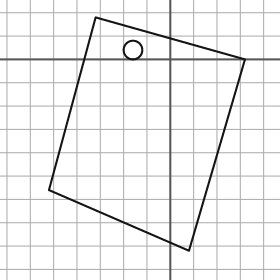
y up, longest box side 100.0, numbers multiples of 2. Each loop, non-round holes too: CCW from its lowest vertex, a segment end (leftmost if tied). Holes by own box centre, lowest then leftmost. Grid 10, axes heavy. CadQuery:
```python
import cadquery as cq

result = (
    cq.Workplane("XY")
    .moveTo(8.0, -82.0)
    .lineTo(32.0, 0.0)
    .lineTo(-32.0, 18.0)
    .lineTo(-52.0, -56.0)
    .close()
    .moveTo(-16.0, 4.0)
    .circle(4.0)
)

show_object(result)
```